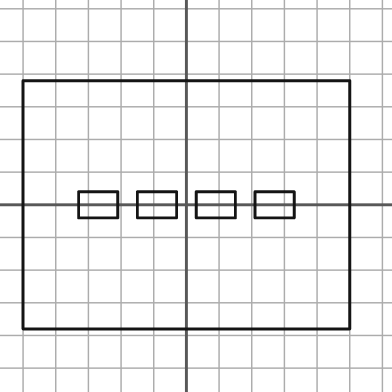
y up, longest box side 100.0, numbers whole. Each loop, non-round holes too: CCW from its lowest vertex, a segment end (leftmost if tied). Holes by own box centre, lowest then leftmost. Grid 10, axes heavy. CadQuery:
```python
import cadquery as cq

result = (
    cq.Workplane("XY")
    .moveTo(-50.0, -38.0)
    .lineTo(50.0, -38.0)
    .lineTo(50.0, 38.0)
    .lineTo(-50.0, 38.0)
    .close()
    .moveTo(-33.0, -4.0)
    .lineTo(-21.0, -4.0)
    .lineTo(-21.0, 4.0)
    .lineTo(-33.0, 4.0)
    .close()
    .moveTo(-15.0, -4.0)
    .lineTo(-3.0, -4.0)
    .lineTo(-3.0, 4.0)
    .lineTo(-15.0, 4.0)
    .close()
    .moveTo(3.0, -4.0)
    .lineTo(15.0, -4.0)
    .lineTo(15.0, 4.0)
    .lineTo(3.0, 4.0)
    .close()
    .moveTo(21.0, -4.0)
    .lineTo(33.0, -4.0)
    .lineTo(33.0, 4.0)
    .lineTo(21.0, 4.0)
    .close()
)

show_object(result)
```